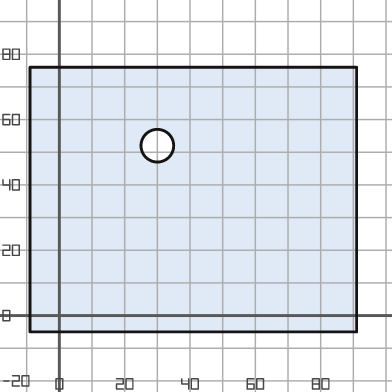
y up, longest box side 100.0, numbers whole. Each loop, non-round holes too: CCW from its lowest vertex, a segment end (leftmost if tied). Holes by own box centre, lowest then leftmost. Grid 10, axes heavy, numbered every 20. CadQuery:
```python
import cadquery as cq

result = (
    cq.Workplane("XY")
    .moveTo(-9.0, -5.0)
    .lineTo(91.0, -5.0)
    .lineTo(91.0, 76.0)
    .lineTo(-9.0, 76.0)
    .close()
    .moveTo(30.0, 52.0)
    .circle(5.0)
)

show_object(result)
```